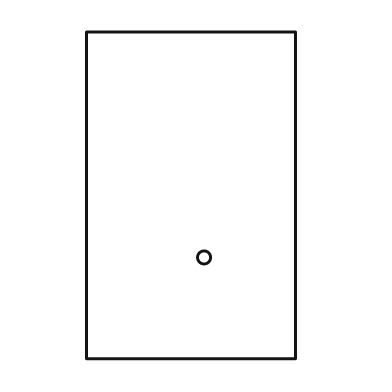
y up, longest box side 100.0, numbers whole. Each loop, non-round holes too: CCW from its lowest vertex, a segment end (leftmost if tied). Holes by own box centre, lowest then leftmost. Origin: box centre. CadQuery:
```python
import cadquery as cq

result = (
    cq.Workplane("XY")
    .moveTo(-32.0, -50.0)
    .lineTo(32.0, -50.0)
    .lineTo(32.0, 50.0)
    .lineTo(-32.0, 50.0)
    .close()
    .moveTo(4.0, -19.0)
    .circle(2.0)
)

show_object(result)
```